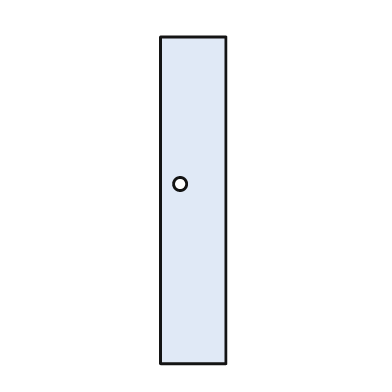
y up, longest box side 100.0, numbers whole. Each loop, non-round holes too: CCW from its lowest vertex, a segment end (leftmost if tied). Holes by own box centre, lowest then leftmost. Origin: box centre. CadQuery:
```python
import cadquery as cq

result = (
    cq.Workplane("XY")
    .moveTo(-10.0, -50.0)
    .lineTo(10.0, -50.0)
    .lineTo(10.0, 50.0)
    .lineTo(-10.0, 50.0)
    .close()
    .moveTo(-4.0, 5.0)
    .circle(2.0)
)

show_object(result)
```